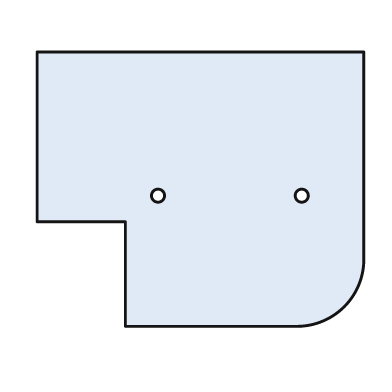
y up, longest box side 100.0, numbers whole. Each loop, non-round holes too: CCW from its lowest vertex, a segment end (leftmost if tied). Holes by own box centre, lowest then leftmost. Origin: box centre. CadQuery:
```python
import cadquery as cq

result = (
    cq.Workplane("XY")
    .moveTo(-23.0, -42.0)
    .lineTo(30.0, -42.0)
    .threePointArc((44.0, -36.0), (50.0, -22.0))
    .lineTo(50.0, 42.0)
    .lineTo(-50.0, 42.0)
    .lineTo(-50.0, -10.0)
    .lineTo(-23.0, -10.0)
    .close()
    .moveTo(-13.0, -2.0)
    .circle(2.0)
    .moveTo(31.0, -2.0)
    .circle(2.0)
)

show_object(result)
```